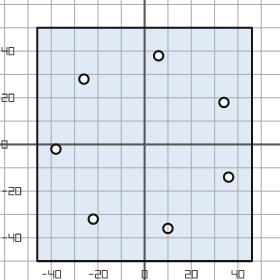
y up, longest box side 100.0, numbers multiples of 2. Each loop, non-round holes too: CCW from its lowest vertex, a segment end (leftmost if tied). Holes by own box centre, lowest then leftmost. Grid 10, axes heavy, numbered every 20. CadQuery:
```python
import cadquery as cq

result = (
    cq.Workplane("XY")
    .moveTo(-46.0, -50.0)
    .lineTo(46.0, -50.0)
    .lineTo(46.0, 50.0)
    .lineTo(-46.0, 50.0)
    .close()
    .moveTo(10.0, -36.0)
    .circle(2.0)
    .moveTo(-22.0, -32.0)
    .circle(2.0)
    .moveTo(36.0, -14.0)
    .circle(2.0)
    .moveTo(-38.0, -2.0)
    .circle(2.0)
    .moveTo(34.0, 18.0)
    .circle(2.0)
    .moveTo(-26.0, 28.0)
    .circle(2.0)
    .moveTo(6.0, 38.0)
    .circle(2.0)
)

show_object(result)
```